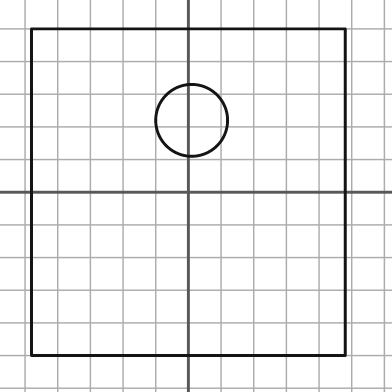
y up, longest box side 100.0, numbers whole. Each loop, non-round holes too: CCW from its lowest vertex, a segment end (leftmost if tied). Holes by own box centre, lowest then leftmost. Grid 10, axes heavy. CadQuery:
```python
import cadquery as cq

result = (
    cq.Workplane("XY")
    .moveTo(-48.0, -50.0)
    .lineTo(48.0, -50.0)
    .lineTo(48.0, 50.0)
    .lineTo(-48.0, 50.0)
    .close()
    .moveTo(1.0, 22.0)
    .circle(11.0)
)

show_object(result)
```